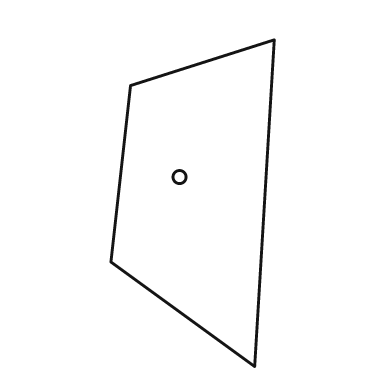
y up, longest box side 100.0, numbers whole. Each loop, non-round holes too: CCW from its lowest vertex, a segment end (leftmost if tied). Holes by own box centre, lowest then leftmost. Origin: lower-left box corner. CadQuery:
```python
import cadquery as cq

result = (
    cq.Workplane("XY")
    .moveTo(44.0, 0.0)
    .lineTo(50.0, 100.0)
    .lineTo(6.0, 86.0)
    .lineTo(0.0, 32.0)
    .close()
    .moveTo(21.0, 58.0)
    .circle(2.0)
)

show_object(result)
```